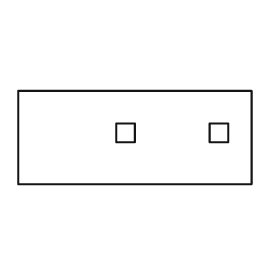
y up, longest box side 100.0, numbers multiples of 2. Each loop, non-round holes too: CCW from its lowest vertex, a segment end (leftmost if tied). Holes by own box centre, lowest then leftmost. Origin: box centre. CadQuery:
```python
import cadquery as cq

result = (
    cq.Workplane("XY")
    .moveTo(-50.0, -20.0)
    .lineTo(50.0, -20.0)
    .lineTo(50.0, 20.0)
    .lineTo(-50.0, 20.0)
    .close()
    .moveTo(-8.0, -2.0)
    .lineTo(0.0, -2.0)
    .lineTo(0.0, 6.0)
    .lineTo(-8.0, 6.0)
    .close()
    .moveTo(32.0, -2.0)
    .lineTo(40.0, -2.0)
    .lineTo(40.0, 6.0)
    .lineTo(32.0, 6.0)
    .close()
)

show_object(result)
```